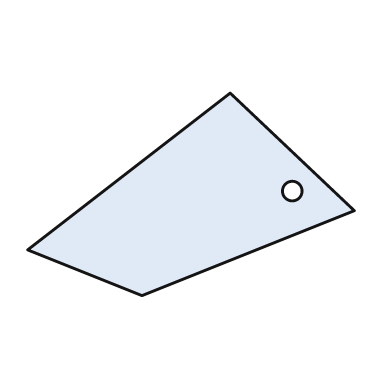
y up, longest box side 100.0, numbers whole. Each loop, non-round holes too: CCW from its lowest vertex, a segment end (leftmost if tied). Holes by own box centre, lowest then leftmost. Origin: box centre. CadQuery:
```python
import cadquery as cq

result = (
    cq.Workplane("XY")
    .moveTo(-15.0, -31.0)
    .lineTo(50.0, -5.0)
    .lineTo(12.0, 31.0)
    .lineTo(-50.0, -17.0)
    .close()
    .moveTo(31.0, 1.0)
    .circle(3.0)
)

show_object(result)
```